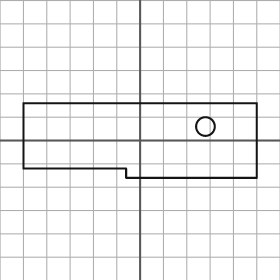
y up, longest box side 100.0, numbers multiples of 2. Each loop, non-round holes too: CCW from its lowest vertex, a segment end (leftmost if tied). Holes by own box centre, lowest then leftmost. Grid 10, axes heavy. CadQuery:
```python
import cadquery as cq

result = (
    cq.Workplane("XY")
    .moveTo(-6.0, -16.0)
    .lineTo(50.0, -16.0)
    .lineTo(50.0, 16.0)
    .lineTo(-50.0, 16.0)
    .lineTo(-50.0, -12.0)
    .lineTo(-6.0, -12.0)
    .close()
    .moveTo(28.0, 6.0)
    .circle(4.0)
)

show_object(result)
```